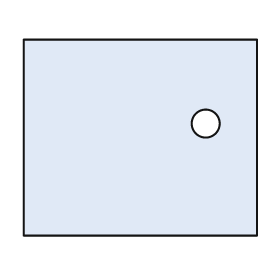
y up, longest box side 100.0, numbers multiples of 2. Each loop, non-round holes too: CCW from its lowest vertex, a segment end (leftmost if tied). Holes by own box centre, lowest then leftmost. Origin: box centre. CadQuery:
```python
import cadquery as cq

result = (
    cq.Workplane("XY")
    .moveTo(-50.0, -42.0)
    .lineTo(50.0, -42.0)
    .lineTo(50.0, 42.0)
    .lineTo(-50.0, 42.0)
    .close()
    .moveTo(28.0, 6.0)
    .circle(6.0)
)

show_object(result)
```